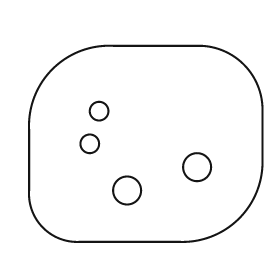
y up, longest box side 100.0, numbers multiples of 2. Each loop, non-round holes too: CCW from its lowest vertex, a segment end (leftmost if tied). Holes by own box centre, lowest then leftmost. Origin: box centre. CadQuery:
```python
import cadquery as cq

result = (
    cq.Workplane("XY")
    .moveTo(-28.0, -42.0)
    .lineTo(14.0, -42.0)
    .threePointArc((40.0, -32.0), (50.0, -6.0))
    .lineTo(50.0, 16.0)
    .threePointArc((42.0, 34.0), (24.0, 42.0))
    .lineTo(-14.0, 42.0)
    .threePointArc((-40.0, 32.0), (-50.0, 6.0))
    .lineTo(-50.0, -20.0)
    .threePointArc((-44.0, -36.0), (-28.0, -42.0))
    .close()
    .moveTo(-8.0, -20.0)
    .circle(6.0)
    .moveTo(22.0, -10.0)
    .circle(6.0)
    .moveTo(-24.0, 0.0)
    .circle(4.0)
    .moveTo(-20.0, 14.0)
    .circle(4.0)
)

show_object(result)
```